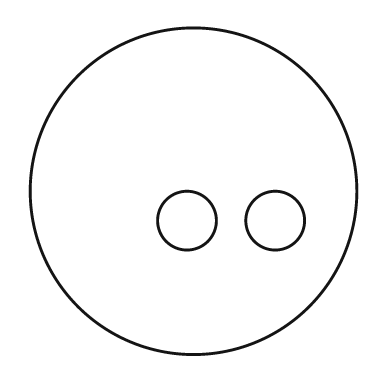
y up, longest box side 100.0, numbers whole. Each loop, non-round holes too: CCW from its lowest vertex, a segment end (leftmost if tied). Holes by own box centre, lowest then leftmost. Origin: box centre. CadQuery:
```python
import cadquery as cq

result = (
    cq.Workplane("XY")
    .moveTo(0.0, 0.0)
    .circle(50.0)
    .moveTo(-2.0, -9.0)
    .circle(9.0)
    .moveTo(25.0, -9.0)
    .circle(9.0)
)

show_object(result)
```